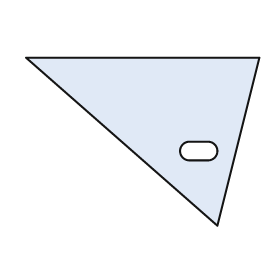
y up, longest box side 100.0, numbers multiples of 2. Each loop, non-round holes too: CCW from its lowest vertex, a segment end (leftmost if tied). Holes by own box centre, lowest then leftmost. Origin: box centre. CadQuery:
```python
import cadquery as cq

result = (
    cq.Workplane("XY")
    .moveTo(32.0, -36.0)
    .lineTo(50.0, 36.0)
    .lineTo(-50.0, 36.0)
    .close()
    .moveTo(20.0, -8.0)
    .lineTo(28.0, -8.0)
    .threePointArc((32.0, -4.0), (28.0, 0.0))
    .lineTo(20.0, 0.0)
    .threePointArc((16.0, -4.0), (20.0, -8.0))
    .close()
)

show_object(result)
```